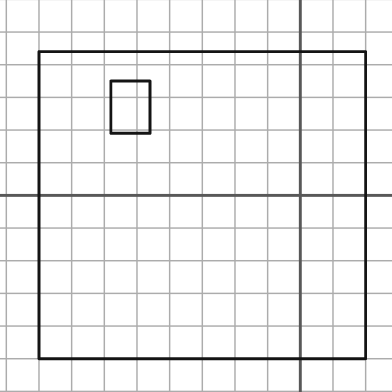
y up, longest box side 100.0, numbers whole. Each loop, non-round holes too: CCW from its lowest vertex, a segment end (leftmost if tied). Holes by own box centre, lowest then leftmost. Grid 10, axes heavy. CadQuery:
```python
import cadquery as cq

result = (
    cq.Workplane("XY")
    .moveTo(-80.0, -50.0)
    .lineTo(20.0, -50.0)
    .lineTo(20.0, 44.0)
    .lineTo(-80.0, 44.0)
    .close()
    .moveTo(-58.0, 19.0)
    .lineTo(-46.0, 19.0)
    .lineTo(-46.0, 35.0)
    .lineTo(-58.0, 35.0)
    .close()
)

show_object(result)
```